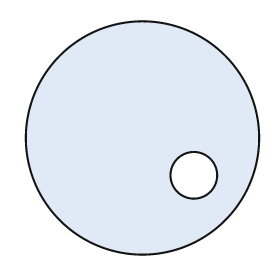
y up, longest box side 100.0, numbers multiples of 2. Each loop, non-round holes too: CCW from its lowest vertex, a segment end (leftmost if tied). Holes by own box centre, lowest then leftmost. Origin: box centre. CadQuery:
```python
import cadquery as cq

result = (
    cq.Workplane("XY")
    .moveTo(0.0, 0.0)
    .circle(50.0)
    .moveTo(22.0, -16.0)
    .circle(10.0)
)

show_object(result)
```